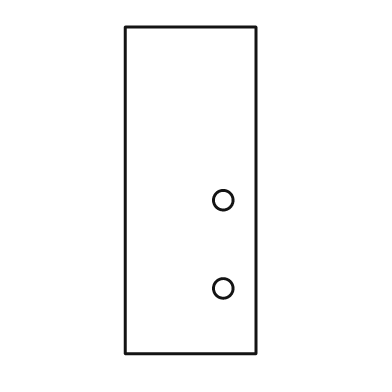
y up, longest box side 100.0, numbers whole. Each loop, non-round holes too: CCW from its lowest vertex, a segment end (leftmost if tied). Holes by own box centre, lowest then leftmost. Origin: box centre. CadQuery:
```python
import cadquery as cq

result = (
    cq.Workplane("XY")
    .moveTo(-20.0, -50.0)
    .lineTo(20.0, -50.0)
    .lineTo(20.0, 50.0)
    .lineTo(-20.0, 50.0)
    .close()
    .moveTo(10.0, -30.0)
    .circle(3.0)
    .moveTo(10.0, -3.0)
    .circle(3.0)
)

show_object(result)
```